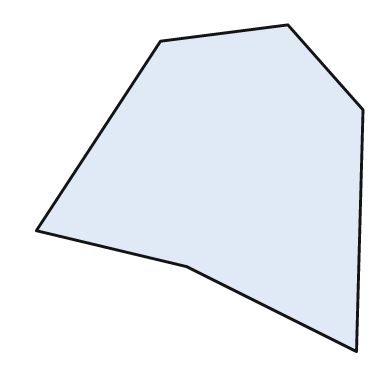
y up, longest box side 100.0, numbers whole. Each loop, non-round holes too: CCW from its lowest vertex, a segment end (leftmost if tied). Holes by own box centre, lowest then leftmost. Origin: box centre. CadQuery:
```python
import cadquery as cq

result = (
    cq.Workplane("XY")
    .moveTo(48.0, -50.0)
    .lineTo(50.0, 24.0)
    .lineTo(27.0, 50.0)
    .lineTo(-12.0, 45.0)
    .lineTo(-50.0, -13.0)
    .lineTo(-4.0, -24.0)
    .close()
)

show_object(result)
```